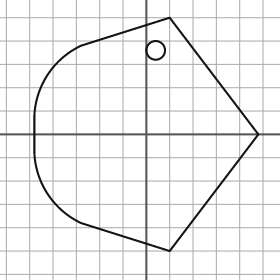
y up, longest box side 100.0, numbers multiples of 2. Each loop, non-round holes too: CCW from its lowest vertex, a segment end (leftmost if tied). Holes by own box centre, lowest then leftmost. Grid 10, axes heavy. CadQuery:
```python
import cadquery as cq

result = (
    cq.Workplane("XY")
    .moveTo(10.0, -50.0)
    .lineTo(48.0, 0.0)
    .lineTo(10.0, 50.0)
    .lineTo(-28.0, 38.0)
    .threePointArc((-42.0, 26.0), (-48.0, 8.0))
    .lineTo(-48.0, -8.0)
    .threePointArc((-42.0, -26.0), (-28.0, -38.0))
    .close()
    .moveTo(4.0, 36.0)
    .circle(4.0)
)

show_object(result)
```